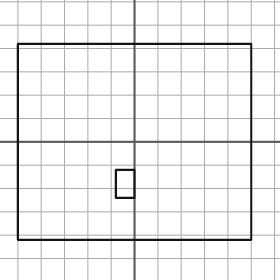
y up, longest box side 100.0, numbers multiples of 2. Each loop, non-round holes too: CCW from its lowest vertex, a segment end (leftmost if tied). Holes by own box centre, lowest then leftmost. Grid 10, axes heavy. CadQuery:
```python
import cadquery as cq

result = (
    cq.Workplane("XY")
    .moveTo(-50.0, -42.0)
    .lineTo(50.0, -42.0)
    .lineTo(50.0, 42.0)
    .lineTo(-50.0, 42.0)
    .close()
    .moveTo(-8.0, -24.0)
    .lineTo(0.0, -24.0)
    .lineTo(0.0, -12.0)
    .lineTo(-8.0, -12.0)
    .close()
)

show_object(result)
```